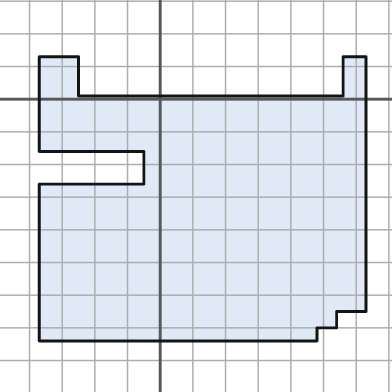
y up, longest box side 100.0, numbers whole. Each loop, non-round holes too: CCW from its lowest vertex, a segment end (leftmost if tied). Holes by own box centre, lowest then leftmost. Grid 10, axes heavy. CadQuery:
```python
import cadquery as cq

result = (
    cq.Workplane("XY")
    .moveTo(-37.0, -74.0)
    .lineTo(48.0, -74.0)
    .lineTo(48.0, -70.0)
    .lineTo(54.0, -70.0)
    .lineTo(54.0, -65.0)
    .lineTo(63.0, -65.0)
    .lineTo(63.0, 13.0)
    .lineTo(56.0, 13.0)
    .lineTo(56.0, 1.0)
    .lineTo(-25.0, 1.0)
    .lineTo(-25.0, 13.0)
    .lineTo(-37.0, 13.0)
    .lineTo(-37.0, -16.0)
    .lineTo(-5.0, -16.0)
    .lineTo(-5.0, -26.0)
    .lineTo(-37.0, -26.0)
    .close()
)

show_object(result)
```